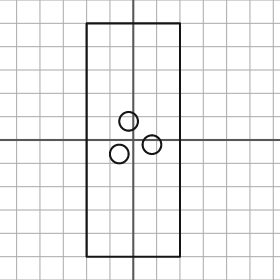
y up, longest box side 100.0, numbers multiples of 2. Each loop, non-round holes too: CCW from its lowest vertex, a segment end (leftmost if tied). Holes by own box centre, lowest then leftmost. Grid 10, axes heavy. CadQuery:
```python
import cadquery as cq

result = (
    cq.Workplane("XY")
    .moveTo(-20.0, -50.0)
    .lineTo(20.0, -50.0)
    .lineTo(20.0, 50.0)
    .lineTo(-20.0, 50.0)
    .close()
    .moveTo(-6.0, -6.0)
    .circle(4.0)
    .moveTo(8.0, -2.0)
    .circle(4.0)
    .moveTo(-2.0, 8.0)
    .circle(4.0)
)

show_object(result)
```